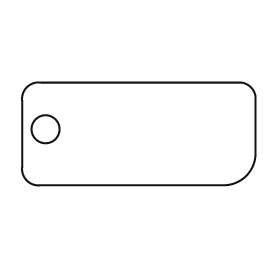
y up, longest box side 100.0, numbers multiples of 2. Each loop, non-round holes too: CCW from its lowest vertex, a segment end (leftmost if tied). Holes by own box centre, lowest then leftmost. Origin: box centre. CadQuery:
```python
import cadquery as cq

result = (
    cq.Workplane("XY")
    .moveTo(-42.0, -22.0)
    .lineTo(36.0, -22.0)
    .threePointArc((46.0, -18.0), (50.0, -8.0))
    .lineTo(50.0, 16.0)
    .threePointArc((48.0, 20.0), (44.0, 22.0))
    .lineTo(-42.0, 22.0)
    .threePointArc((-48.0, 20.0), (-50.0, 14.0))
    .lineTo(-50.0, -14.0)
    .threePointArc((-48.0, -20.0), (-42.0, -22.0))
    .close()
    .moveTo(-40.0, 2.0)
    .circle(6.0)
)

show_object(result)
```